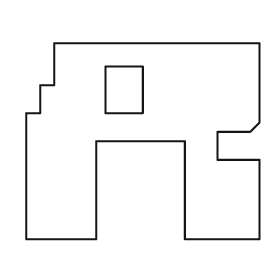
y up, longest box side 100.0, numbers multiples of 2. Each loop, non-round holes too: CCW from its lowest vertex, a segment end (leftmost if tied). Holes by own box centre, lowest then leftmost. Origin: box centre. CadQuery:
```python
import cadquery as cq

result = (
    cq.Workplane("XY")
    .moveTo(-50.0, -42.0)
    .lineTo(-20.0, -42.0)
    .lineTo(-20.0, 0.0)
    .lineTo(18.0, 0.0)
    .lineTo(18.0, -42.0)
    .lineTo(50.0, -42.0)
    .lineTo(50.0, -8.0)
    .lineTo(32.0, -8.0)
    .lineTo(32.0, 4.0)
    .lineTo(46.0, 4.0)
    .lineTo(50.0, 8.0)
    .lineTo(50.0, 42.0)
    .lineTo(-38.0, 42.0)
    .lineTo(-38.0, 24.0)
    .lineTo(-44.0, 24.0)
    .lineTo(-44.0, 12.0)
    .lineTo(-50.0, 12.0)
    .close()
    .moveTo(-16.0, 12.0)
    .lineTo(0.0, 12.0)
    .lineTo(0.0, 32.0)
    .lineTo(-16.0, 32.0)
    .close()
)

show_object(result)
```